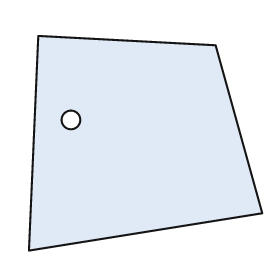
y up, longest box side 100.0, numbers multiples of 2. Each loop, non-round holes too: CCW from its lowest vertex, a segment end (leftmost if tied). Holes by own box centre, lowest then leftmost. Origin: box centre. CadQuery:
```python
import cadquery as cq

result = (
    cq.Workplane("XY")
    .moveTo(-50.0, -46.0)
    .lineTo(50.0, -30.0)
    .lineTo(30.0, 42.0)
    .lineTo(-46.0, 46.0)
    .close()
    .moveTo(-32.0, 10.0)
    .circle(4.0)
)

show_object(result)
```